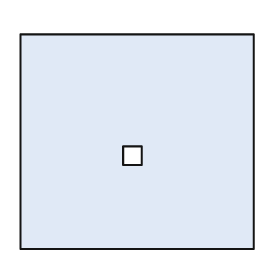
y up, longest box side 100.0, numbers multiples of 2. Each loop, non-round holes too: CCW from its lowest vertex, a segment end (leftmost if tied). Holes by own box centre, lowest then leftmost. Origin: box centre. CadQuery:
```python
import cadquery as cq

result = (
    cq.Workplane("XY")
    .moveTo(-50.0, -46.0)
    .lineTo(50.0, -46.0)
    .lineTo(50.0, 46.0)
    .lineTo(-50.0, 46.0)
    .close()
    .moveTo(-6.0, -10.0)
    .lineTo(2.0, -10.0)
    .lineTo(2.0, -2.0)
    .lineTo(-6.0, -2.0)
    .close()
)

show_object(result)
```